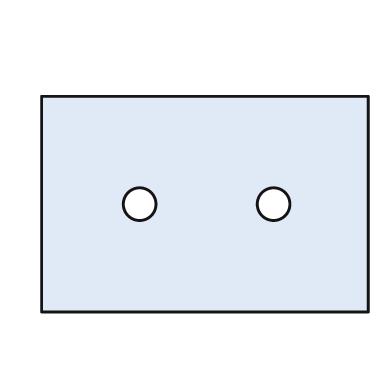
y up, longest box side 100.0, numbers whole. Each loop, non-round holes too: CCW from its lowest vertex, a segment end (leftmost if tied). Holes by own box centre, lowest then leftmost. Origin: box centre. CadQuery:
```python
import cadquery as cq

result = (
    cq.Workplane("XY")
    .moveTo(-50.0, -33.0)
    .lineTo(50.0, -33.0)
    .lineTo(50.0, 33.0)
    .lineTo(-50.0, 33.0)
    .close()
    .moveTo(-20.0, 0.0)
    .circle(5.0)
    .moveTo(21.0, 0.0)
    .circle(5.0)
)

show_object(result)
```